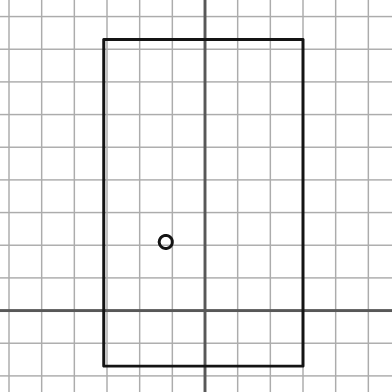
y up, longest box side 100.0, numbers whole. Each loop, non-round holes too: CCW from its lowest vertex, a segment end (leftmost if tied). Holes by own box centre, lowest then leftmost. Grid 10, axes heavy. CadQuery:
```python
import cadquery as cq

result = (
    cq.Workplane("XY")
    .moveTo(-31.0, -17.0)
    .lineTo(30.0, -17.0)
    .lineTo(30.0, 83.0)
    .lineTo(-31.0, 83.0)
    .close()
    .moveTo(-12.0, 21.0)
    .circle(2.0)
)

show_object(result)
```